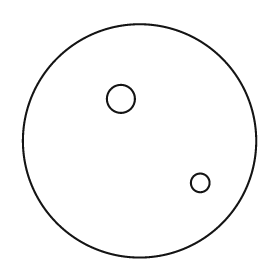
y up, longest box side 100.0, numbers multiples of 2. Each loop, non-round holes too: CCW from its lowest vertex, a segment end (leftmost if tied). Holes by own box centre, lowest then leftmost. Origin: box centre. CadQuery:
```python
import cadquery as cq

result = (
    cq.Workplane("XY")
    .moveTo(0.0, 0.0)
    .circle(50.0)
    .moveTo(26.0, -18.0)
    .circle(4.0)
    .moveTo(-8.0, 18.0)
    .circle(6.0)
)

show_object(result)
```